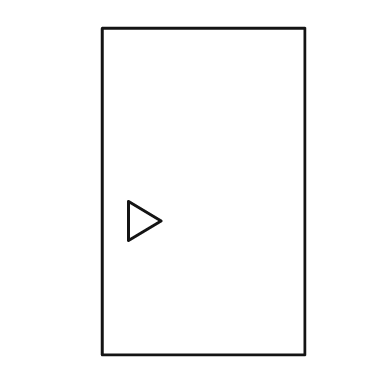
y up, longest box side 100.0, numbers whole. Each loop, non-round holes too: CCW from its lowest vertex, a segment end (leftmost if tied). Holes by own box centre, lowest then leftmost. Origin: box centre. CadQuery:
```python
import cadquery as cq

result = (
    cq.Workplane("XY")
    .moveTo(-31.0, -50.0)
    .lineTo(31.0, -50.0)
    .lineTo(31.0, 50.0)
    .lineTo(-31.0, 50.0)
    .close()
    .moveTo(-23.0, -15.0)
    .lineTo(-13.0, -9.0)
    .lineTo(-23.0, -3.0)
    .close()
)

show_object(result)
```